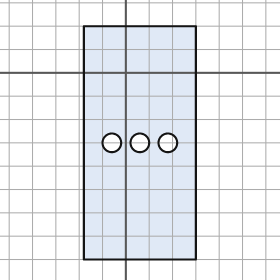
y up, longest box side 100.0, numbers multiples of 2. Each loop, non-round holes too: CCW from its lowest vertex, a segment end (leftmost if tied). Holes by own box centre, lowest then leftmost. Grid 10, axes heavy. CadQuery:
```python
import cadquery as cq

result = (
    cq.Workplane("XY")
    .moveTo(-18.0, -80.0)
    .lineTo(30.0, -80.0)
    .lineTo(30.0, 20.0)
    .lineTo(-18.0, 20.0)
    .close()
    .moveTo(-6.0, -30.0)
    .circle(4.0)
    .moveTo(6.0, -30.0)
    .circle(4.0)
    .moveTo(18.0, -30.0)
    .circle(4.0)
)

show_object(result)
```